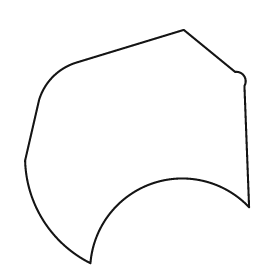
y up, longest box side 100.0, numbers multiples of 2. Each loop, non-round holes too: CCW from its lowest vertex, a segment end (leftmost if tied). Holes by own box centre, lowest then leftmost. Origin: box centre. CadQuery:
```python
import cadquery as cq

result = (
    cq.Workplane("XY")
    .moveTo(-20.0, -50.0)
    .threePointArc((6.0, -16.0), (48.0, -26.0))
    .lineTo(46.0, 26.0)
    .threePointArc((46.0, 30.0), (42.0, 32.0))
    .lineTo(20.0, 50.0)
    .lineTo(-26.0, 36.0)
    .threePointArc((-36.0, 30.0), (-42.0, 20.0))
    .lineTo(-48.0, -6.0)
    .threePointArc((-40.0, -32.0), (-20.0, -50.0))
    .close()
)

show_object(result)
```